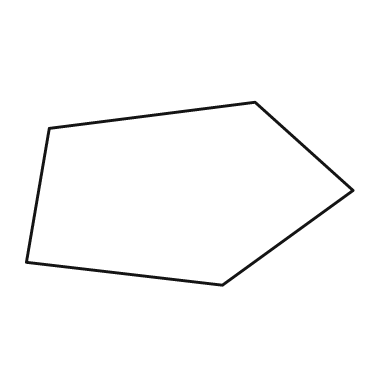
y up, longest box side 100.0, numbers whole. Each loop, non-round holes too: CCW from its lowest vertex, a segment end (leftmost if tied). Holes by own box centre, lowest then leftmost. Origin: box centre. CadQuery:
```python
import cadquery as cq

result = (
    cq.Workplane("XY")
    .moveTo(10.0, -28.0)
    .lineTo(50.0, 1.0)
    .lineTo(20.0, 28.0)
    .lineTo(-43.0, 20.0)
    .lineTo(-50.0, -21.0)
    .close()
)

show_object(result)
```